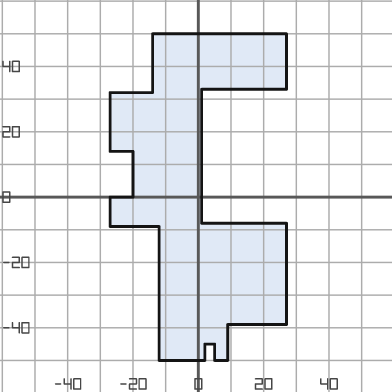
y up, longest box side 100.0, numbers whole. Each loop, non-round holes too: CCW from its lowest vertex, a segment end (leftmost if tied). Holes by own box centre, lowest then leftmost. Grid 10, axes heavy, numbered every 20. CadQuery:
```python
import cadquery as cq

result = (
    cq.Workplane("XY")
    .moveTo(-12.0, -50.0)
    .lineTo(2.0, -50.0)
    .lineTo(2.0, -45.0)
    .lineTo(5.0, -45.0)
    .lineTo(5.0, -50.0)
    .lineTo(9.0, -50.0)
    .lineTo(9.0, -39.0)
    .lineTo(27.0, -39.0)
    .lineTo(27.0, -8.0)
    .lineTo(1.0, -8.0)
    .lineTo(1.0, 33.0)
    .lineTo(27.0, 33.0)
    .lineTo(27.0, 50.0)
    .lineTo(-14.0, 50.0)
    .lineTo(-14.0, 32.0)
    .lineTo(-27.0, 32.0)
    .lineTo(-27.0, 14.0)
    .lineTo(-20.0, 14.0)
    .lineTo(-20.0, 0.0)
    .lineTo(-27.0, 0.0)
    .lineTo(-27.0, -9.0)
    .lineTo(-12.0, -9.0)
    .close()
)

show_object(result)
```